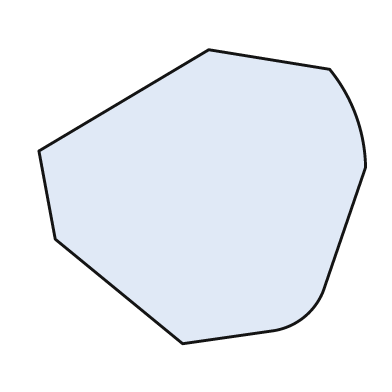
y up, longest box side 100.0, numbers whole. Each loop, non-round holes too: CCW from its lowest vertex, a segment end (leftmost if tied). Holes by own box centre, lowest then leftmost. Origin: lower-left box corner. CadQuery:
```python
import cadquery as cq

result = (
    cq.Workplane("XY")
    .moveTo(44.0, 0.0)
    .lineTo(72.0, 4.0)
    .threePointArc((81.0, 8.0), (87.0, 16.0))
    .lineTo(100.0, 54.0)
    .threePointArc((97.0, 70.0), (89.0, 84.0))
    .lineTo(52.0, 90.0)
    .lineTo(0.0, 59.0)
    .lineTo(5.0, 32.0)
    .close()
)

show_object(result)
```